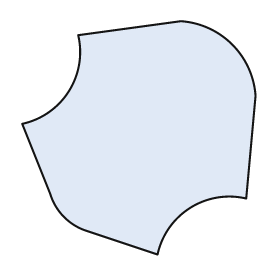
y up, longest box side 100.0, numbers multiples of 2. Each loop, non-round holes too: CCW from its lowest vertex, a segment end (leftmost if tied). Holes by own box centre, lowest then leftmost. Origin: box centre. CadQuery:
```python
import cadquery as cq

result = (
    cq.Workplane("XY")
    .moveTo(8.0, -50.0)
    .threePointArc((22.0, -30.0), (46.0, -26.0))
    .lineTo(50.0, 18.0)
    .threePointArc((40.0, 40.0), (18.0, 50.0))
    .lineTo(-26.0, 44.0)
    .threePointArc((-30.0, 20.0), (-50.0, 6.0))
    .lineTo(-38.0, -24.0)
    .threePointArc((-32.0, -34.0), (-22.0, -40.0))
    .close()
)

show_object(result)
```